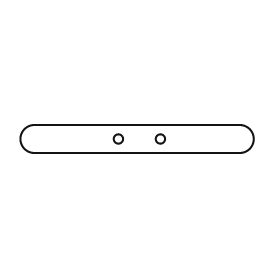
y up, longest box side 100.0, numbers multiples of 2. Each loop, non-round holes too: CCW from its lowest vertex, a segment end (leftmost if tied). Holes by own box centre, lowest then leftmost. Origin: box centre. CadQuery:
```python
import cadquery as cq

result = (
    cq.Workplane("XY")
    .moveTo(-44.0, -6.0)
    .lineTo(44.0, -6.0)
    .threePointArc((50.0, 0.0), (44.0, 6.0))
    .lineTo(-44.0, 6.0)
    .threePointArc((-50.0, 0.0), (-44.0, -6.0))
    .close()
    .moveTo(-8.0, 0.0)
    .circle(2.0)
    .moveTo(10.0, 0.0)
    .circle(2.0)
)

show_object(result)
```